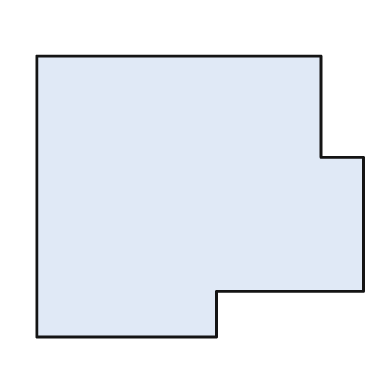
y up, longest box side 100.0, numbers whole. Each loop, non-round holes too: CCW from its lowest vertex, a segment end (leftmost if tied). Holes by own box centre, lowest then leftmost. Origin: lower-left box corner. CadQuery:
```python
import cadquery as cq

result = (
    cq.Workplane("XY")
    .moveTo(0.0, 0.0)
    .lineTo(55.0, 0.0)
    .lineTo(55.0, 14.0)
    .lineTo(100.0, 14.0)
    .lineTo(100.0, 55.0)
    .lineTo(87.0, 55.0)
    .lineTo(87.0, 86.0)
    .lineTo(0.0, 86.0)
    .close()
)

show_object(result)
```